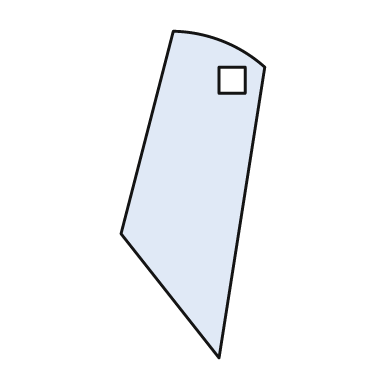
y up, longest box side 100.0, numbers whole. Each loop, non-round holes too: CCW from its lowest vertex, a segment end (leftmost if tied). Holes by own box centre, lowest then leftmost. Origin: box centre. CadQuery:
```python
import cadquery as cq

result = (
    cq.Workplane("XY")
    .moveTo(8.0, -50.0)
    .lineTo(22.0, 39.0)
    .threePointArc((9.0, 47.0), (-6.0, 50.0))
    .lineTo(-22.0, -12.0)
    .close()
    .moveTo(8.0, 31.0)
    .lineTo(16.0, 31.0)
    .lineTo(16.0, 39.0)
    .lineTo(8.0, 39.0)
    .close()
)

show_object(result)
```